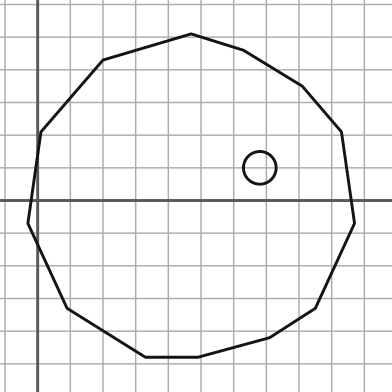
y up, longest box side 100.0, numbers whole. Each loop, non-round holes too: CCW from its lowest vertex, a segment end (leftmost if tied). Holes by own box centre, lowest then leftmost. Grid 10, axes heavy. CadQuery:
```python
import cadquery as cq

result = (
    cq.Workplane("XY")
    .moveTo(33.0, -48.0)
    .lineTo(49.0, -48.0)
    .lineTo(71.0, -42.0)
    .lineTo(85.0, -33.0)
    .lineTo(97.0, -7.0)
    .lineTo(93.0, 21.0)
    .lineTo(81.0, 35.0)
    .lineTo(63.0, 46.0)
    .lineTo(47.0, 51.0)
    .lineTo(20.0, 43.0)
    .lineTo(1.0, 21.0)
    .lineTo(-3.0, -7.0)
    .lineTo(9.0, -33.0)
    .close()
    .moveTo(68.0, 10.0)
    .circle(5.0)
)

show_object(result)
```